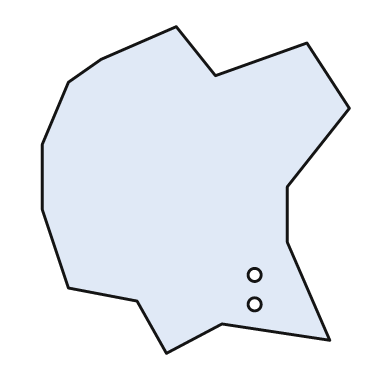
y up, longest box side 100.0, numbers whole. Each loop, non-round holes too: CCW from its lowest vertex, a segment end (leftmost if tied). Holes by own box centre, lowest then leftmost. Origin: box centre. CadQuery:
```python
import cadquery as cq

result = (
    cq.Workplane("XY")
    .moveTo(-9.0, -50.0)
    .lineTo(8.0, -41.0)
    .lineTo(41.0, -46.0)
    .lineTo(28.0, -16.0)
    .lineTo(28.0, 1.0)
    .lineTo(47.0, 25.0)
    .lineTo(34.0, 45.0)
    .lineTo(6.0, 35.0)
    .lineTo(-6.0, 50.0)
    .lineTo(-29.0, 40.0)
    .lineTo(-39.0, 33.0)
    .lineTo(-47.0, 14.0)
    .lineTo(-47.0, -6.0)
    .lineTo(-39.0, -30.0)
    .lineTo(-18.0, -34.0)
    .close()
    .moveTo(18.0, -35.0)
    .circle(2.0)
    .moveTo(18.0, -26.0)
    .circle(2.0)
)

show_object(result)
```